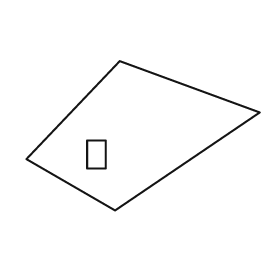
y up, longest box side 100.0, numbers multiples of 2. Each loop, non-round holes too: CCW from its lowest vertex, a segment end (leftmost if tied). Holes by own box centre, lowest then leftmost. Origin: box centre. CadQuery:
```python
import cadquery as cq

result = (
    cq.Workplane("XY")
    .moveTo(-12.0, -32.0)
    .lineTo(50.0, 10.0)
    .lineTo(-10.0, 32.0)
    .lineTo(-50.0, -10.0)
    .close()
    .moveTo(-24.0, -14.0)
    .lineTo(-16.0, -14.0)
    .lineTo(-16.0, -2.0)
    .lineTo(-24.0, -2.0)
    .close()
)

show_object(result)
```